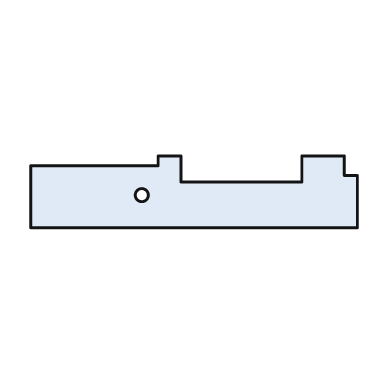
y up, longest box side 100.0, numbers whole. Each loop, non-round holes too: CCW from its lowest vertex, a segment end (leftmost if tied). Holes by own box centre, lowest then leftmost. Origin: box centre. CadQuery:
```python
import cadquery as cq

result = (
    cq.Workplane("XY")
    .moveTo(-50.0, -11.0)
    .lineTo(50.0, -11.0)
    .lineTo(50.0, 5.0)
    .lineTo(46.0, 5.0)
    .lineTo(46.0, 11.0)
    .lineTo(33.0, 11.0)
    .lineTo(33.0, 3.0)
    .lineTo(-4.0, 3.0)
    .lineTo(-4.0, 11.0)
    .lineTo(-11.0, 11.0)
    .lineTo(-11.0, 8.0)
    .lineTo(-50.0, 8.0)
    .close()
    .moveTo(-16.0, -1.0)
    .circle(2.0)
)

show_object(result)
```